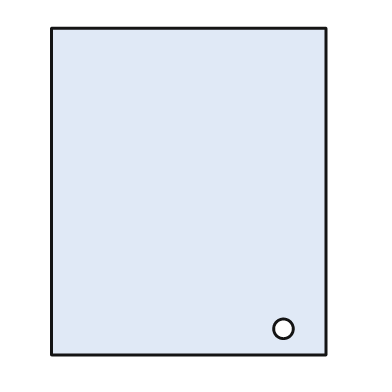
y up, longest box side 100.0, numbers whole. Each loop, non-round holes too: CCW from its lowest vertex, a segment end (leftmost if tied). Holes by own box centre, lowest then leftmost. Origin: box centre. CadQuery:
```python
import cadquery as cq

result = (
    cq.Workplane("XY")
    .moveTo(-42.0, -50.0)
    .lineTo(42.0, -50.0)
    .lineTo(42.0, 50.0)
    .lineTo(-42.0, 50.0)
    .close()
    .moveTo(29.0, -42.0)
    .circle(3.0)
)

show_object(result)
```